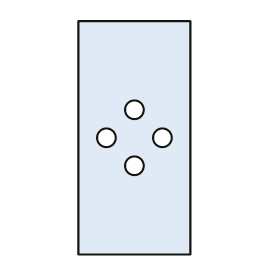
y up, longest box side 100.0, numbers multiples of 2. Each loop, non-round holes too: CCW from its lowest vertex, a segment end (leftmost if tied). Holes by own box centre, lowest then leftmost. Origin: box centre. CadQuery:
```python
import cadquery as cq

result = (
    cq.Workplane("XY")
    .moveTo(-24.0, -50.0)
    .lineTo(24.0, -50.0)
    .lineTo(24.0, 50.0)
    .lineTo(-24.0, 50.0)
    .close()
    .moveTo(0.0, -12.0)
    .circle(4.0)
    .moveTo(-12.0, 0.0)
    .circle(4.0)
    .moveTo(12.0, 0.0)
    .circle(4.0)
    .moveTo(0.0, 12.0)
    .circle(4.0)
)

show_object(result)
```